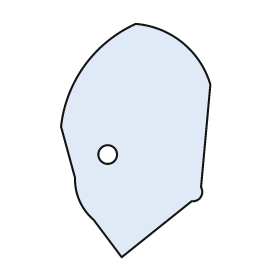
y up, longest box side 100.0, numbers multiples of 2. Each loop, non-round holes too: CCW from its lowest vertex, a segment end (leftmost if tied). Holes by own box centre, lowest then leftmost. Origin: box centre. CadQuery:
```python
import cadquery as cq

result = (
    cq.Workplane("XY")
    .moveTo(-6.0, -50.0)
    .lineTo(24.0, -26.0)
    .threePointArc((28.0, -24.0), (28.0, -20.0))
    .lineTo(32.0, 24.0)
    .threePointArc((20.0, 42.0), (0.0, 50.0))
    .threePointArc((-22.0, 32.0), (-32.0, 6.0))
    .lineTo(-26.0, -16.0)
    .threePointArc((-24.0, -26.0), (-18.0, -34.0))
    .close()
    .moveTo(-12.0, -6.0)
    .circle(4.0)
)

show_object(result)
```